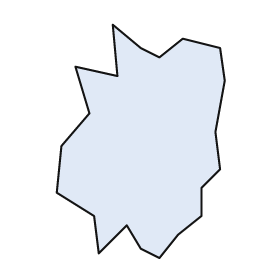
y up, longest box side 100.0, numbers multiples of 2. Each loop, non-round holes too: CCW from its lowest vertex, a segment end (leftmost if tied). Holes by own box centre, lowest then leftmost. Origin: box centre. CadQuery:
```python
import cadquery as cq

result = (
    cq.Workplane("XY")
    .moveTo(8.0, -50.0)
    .lineTo(16.0, -40.0)
    .lineTo(26.0, -32.0)
    .lineTo(26.0, -20.0)
    .lineTo(34.0, -12.0)
    .lineTo(32.0, 4.0)
    .lineTo(36.0, 26.0)
    .lineTo(34.0, 40.0)
    .lineTo(18.0, 44.0)
    .lineTo(8.0, 36.0)
    .lineTo(0.0, 40.0)
    .lineTo(-12.0, 50.0)
    .lineTo(-10.0, 28.0)
    .lineTo(-28.0, 32.0)
    .lineTo(-22.0, 12.0)
    .lineTo(-34.0, -2.0)
    .lineTo(-36.0, -22.0)
    .lineTo(-20.0, -32.0)
    .lineTo(-18.0, -48.0)
    .lineTo(-6.0, -36.0)
    .lineTo(0.0, -46.0)
    .close()
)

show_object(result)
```